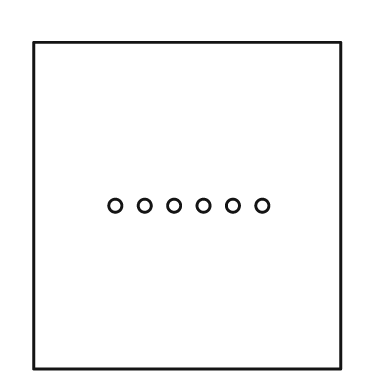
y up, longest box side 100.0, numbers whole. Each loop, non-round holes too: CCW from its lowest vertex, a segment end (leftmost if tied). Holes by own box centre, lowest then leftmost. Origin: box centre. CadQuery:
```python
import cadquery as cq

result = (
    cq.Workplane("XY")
    .moveTo(-47.0, -50.0)
    .lineTo(47.0, -50.0)
    .lineTo(47.0, 50.0)
    .lineTo(-47.0, 50.0)
    .close()
    .moveTo(-22.0, 0.0)
    .circle(2.0)
    .moveTo(-13.0, 0.0)
    .circle(2.0)
    .moveTo(-4.0, 0.0)
    .circle(2.0)
    .moveTo(5.0, 0.0)
    .circle(2.0)
    .moveTo(14.0, 0.0)
    .circle(2.0)
    .moveTo(23.0, 0.0)
    .circle(2.0)
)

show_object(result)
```